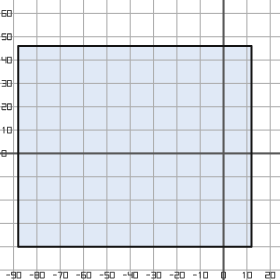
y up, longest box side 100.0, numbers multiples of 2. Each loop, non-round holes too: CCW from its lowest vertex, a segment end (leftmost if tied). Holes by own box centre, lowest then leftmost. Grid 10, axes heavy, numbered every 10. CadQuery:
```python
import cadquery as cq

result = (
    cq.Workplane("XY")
    .moveTo(-88.0, -40.0)
    .lineTo(12.0, -40.0)
    .lineTo(12.0, 46.0)
    .lineTo(-88.0, 46.0)
    .close()
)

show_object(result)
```